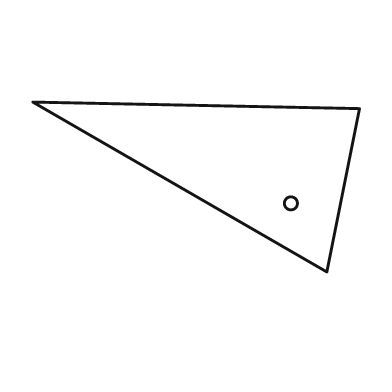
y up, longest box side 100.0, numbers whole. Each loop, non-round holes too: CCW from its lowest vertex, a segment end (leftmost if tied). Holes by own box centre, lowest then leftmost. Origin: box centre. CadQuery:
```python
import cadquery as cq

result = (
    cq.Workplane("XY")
    .moveTo(40.0, -26.0)
    .lineTo(50.0, 24.0)
    .lineTo(-50.0, 26.0)
    .close()
    .moveTo(29.0, -5.0)
    .circle(2.0)
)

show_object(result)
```